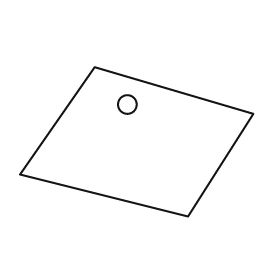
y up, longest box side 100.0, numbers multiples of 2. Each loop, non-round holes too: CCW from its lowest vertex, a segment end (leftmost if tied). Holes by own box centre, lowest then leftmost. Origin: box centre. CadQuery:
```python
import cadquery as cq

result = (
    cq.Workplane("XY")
    .moveTo(22.0, -32.0)
    .lineTo(50.0, 12.0)
    .lineTo(-18.0, 32.0)
    .lineTo(-50.0, -14.0)
    .close()
    .moveTo(-4.0, 16.0)
    .circle(4.0)
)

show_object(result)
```